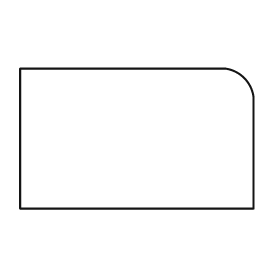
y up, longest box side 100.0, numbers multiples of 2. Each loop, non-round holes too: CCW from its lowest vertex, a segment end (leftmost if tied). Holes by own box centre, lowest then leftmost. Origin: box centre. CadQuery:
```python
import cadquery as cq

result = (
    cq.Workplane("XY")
    .moveTo(-50.0, -30.0)
    .lineTo(50.0, -30.0)
    .lineTo(50.0, 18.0)
    .threePointArc((46.0, 26.0), (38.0, 30.0))
    .lineTo(-50.0, 30.0)
    .close()
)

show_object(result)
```